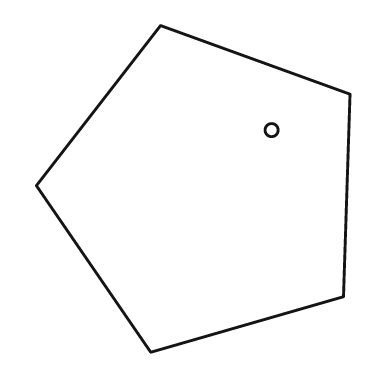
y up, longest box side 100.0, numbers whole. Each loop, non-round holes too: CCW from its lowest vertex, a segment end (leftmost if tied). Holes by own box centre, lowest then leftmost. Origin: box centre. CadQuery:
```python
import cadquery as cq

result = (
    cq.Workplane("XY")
    .moveTo(-13.0, -50.0)
    .lineTo(46.0, -33.0)
    .lineTo(48.0, 29.0)
    .lineTo(-10.0, 50.0)
    .lineTo(-48.0, 1.0)
    .close()
    .moveTo(24.0, 18.0)
    .circle(2.0)
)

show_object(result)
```